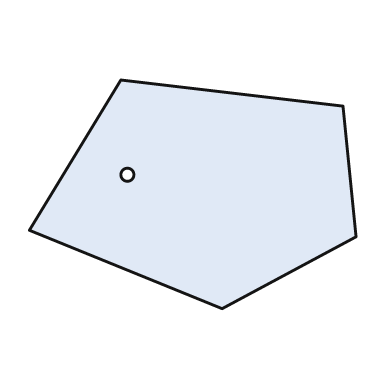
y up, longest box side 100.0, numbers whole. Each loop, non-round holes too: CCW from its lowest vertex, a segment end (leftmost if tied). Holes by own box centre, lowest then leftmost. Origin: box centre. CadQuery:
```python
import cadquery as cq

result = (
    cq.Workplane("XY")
    .moveTo(9.0, -35.0)
    .lineTo(50.0, -13.0)
    .lineTo(46.0, 27.0)
    .lineTo(-22.0, 35.0)
    .lineTo(-50.0, -11.0)
    .close()
    .moveTo(-20.0, 6.0)
    .circle(2.0)
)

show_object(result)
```